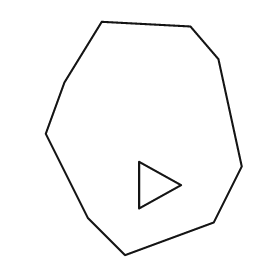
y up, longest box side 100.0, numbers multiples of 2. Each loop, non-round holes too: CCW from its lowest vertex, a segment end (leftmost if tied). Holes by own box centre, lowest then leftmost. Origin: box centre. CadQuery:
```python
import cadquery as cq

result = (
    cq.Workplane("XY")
    .moveTo(-8.0, -50.0)
    .lineTo(30.0, -36.0)
    .lineTo(42.0, -12.0)
    .lineTo(32.0, 34.0)
    .lineTo(20.0, 48.0)
    .lineTo(-18.0, 50.0)
    .lineTo(-34.0, 24.0)
    .lineTo(-42.0, 2.0)
    .lineTo(-24.0, -34.0)
    .close()
    .moveTo(-2.0, -30.0)
    .lineTo(16.0, -20.0)
    .lineTo(-2.0, -10.0)
    .close()
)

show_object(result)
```